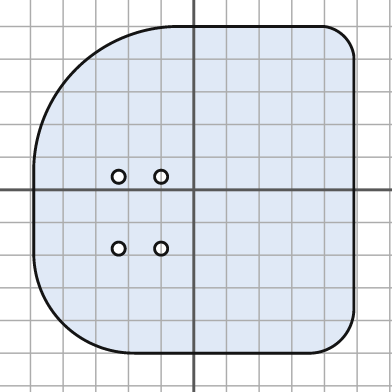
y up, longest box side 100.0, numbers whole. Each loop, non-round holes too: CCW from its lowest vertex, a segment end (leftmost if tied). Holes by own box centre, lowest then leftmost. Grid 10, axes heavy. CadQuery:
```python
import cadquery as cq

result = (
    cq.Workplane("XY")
    .moveTo(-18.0, -50.0)
    .lineTo(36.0, -50.0)
    .threePointArc((45.0, -46.0), (49.0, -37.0))
    .lineTo(49.0, 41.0)
    .threePointArc((46.0, 47.0), (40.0, 50.0))
    .lineTo(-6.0, 50.0)
    .threePointArc((-36.0, 37.0), (-49.0, 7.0))
    .lineTo(-49.0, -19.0)
    .threePointArc((-40.0, -41.0), (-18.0, -50.0))
    .close()
    .moveTo(-23.0, -18.0)
    .circle(2.0)
    .moveTo(-10.0, -18.0)
    .circle(2.0)
    .moveTo(-23.0, 4.0)
    .circle(2.0)
    .moveTo(-10.0, 4.0)
    .circle(2.0)
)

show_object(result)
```